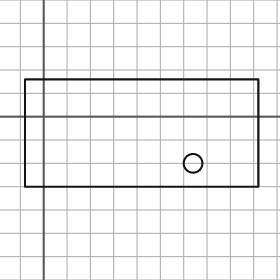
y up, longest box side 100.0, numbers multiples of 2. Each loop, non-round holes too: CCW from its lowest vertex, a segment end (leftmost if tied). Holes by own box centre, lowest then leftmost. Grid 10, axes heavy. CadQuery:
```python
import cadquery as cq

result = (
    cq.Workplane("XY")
    .moveTo(-8.0, -30.0)
    .lineTo(92.0, -30.0)
    .lineTo(92.0, 16.0)
    .lineTo(-8.0, 16.0)
    .close()
    .moveTo(64.0, -20.0)
    .circle(4.0)
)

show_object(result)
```